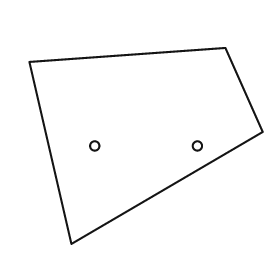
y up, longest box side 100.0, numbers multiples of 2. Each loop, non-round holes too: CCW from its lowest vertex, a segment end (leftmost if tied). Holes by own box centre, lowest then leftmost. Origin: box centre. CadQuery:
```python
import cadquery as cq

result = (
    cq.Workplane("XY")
    .moveTo(-32.0, -42.0)
    .lineTo(50.0, 6.0)
    .lineTo(34.0, 42.0)
    .lineTo(-50.0, 36.0)
    .close()
    .moveTo(-22.0, 0.0)
    .circle(2.0)
    .moveTo(22.0, 0.0)
    .circle(2.0)
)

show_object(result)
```